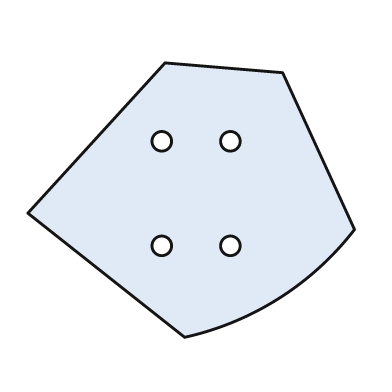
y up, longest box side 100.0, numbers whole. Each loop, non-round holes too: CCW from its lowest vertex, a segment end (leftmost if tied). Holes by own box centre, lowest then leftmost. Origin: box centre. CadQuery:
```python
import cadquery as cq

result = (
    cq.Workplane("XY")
    .moveTo(-2.0, -42.0)
    .threePointArc((27.0, -30.0), (50.0, -9.0))
    .lineTo(28.0, 39.0)
    .lineTo(-8.0, 42.0)
    .lineTo(-50.0, -4.0)
    .close()
    .moveTo(-9.0, -14.0)
    .circle(3.0)
    .moveTo(12.0, -14.0)
    .circle(3.0)
    .moveTo(-9.0, 18.0)
    .circle(3.0)
    .moveTo(12.0, 18.0)
    .circle(3.0)
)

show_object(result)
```